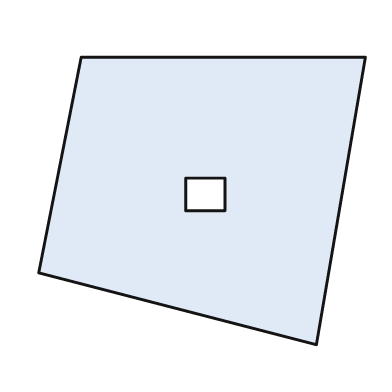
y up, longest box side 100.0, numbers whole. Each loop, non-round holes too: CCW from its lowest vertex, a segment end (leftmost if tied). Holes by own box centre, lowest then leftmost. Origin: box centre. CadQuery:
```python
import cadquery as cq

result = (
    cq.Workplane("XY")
    .moveTo(35.0, -44.0)
    .lineTo(50.0, 44.0)
    .lineTo(-37.0, 44.0)
    .lineTo(-50.0, -22.0)
    .close()
    .moveTo(-5.0, -3.0)
    .lineTo(7.0, -3.0)
    .lineTo(7.0, 7.0)
    .lineTo(-5.0, 7.0)
    .close()
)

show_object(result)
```